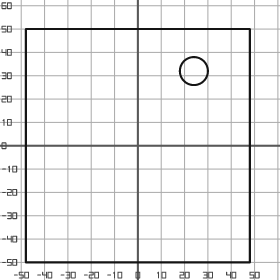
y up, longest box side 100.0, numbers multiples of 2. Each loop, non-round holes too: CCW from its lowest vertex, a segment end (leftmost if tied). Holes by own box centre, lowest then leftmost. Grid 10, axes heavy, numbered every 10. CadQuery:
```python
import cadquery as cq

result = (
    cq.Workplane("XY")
    .moveTo(-48.0, -50.0)
    .lineTo(48.0, -50.0)
    .lineTo(48.0, 50.0)
    .lineTo(-48.0, 50.0)
    .close()
    .moveTo(24.0, 32.0)
    .circle(6.0)
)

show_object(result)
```